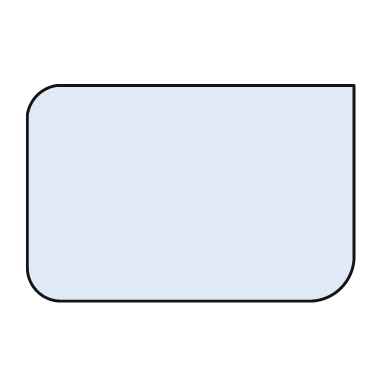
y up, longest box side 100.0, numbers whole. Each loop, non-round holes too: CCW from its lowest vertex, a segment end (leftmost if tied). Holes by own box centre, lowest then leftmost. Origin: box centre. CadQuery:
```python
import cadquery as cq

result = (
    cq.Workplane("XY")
    .moveTo(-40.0, -33.0)
    .lineTo(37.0, -33.0)
    .threePointArc((46.0, -29.0), (50.0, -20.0))
    .lineTo(50.0, 33.0)
    .lineTo(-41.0, 33.0)
    .threePointArc((-47.0, 30.0), (-50.0, 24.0))
    .lineTo(-50.0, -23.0)
    .threePointArc((-47.0, -30.0), (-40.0, -33.0))
    .close()
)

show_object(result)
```